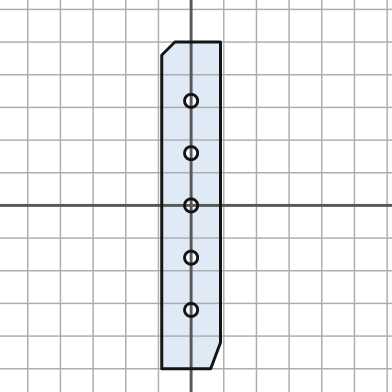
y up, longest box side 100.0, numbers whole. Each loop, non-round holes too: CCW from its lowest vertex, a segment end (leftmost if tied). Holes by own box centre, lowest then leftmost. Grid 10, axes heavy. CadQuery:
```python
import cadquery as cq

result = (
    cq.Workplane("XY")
    .moveTo(-9.0, -50.0)
    .lineTo(6.0, -50.0)
    .lineTo(9.0, -42.0)
    .lineTo(9.0, 50.0)
    .lineTo(-5.0, 50.0)
    .lineTo(-9.0, 46.0)
    .close()
    .moveTo(0.0, -32.0)
    .circle(2.0)
    .moveTo(0.0, -16.0)
    .circle(2.0)
    .moveTo(0.0, 0.0)
    .circle(2.0)
    .moveTo(0.0, 16.0)
    .circle(2.0)
    .moveTo(0.0, 32.0)
    .circle(2.0)
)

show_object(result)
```